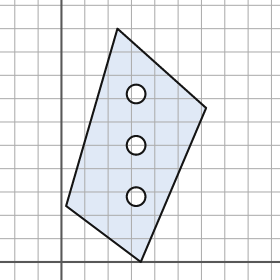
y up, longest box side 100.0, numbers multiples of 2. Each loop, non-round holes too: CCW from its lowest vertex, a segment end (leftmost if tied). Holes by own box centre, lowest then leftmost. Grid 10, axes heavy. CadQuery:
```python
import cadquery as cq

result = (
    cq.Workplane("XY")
    .moveTo(34.0, 0.0)
    .lineTo(62.0, 66.0)
    .lineTo(24.0, 100.0)
    .lineTo(2.0, 24.0)
    .close()
    .moveTo(32.0, 28.0)
    .circle(4.0)
    .moveTo(32.0, 50.0)
    .circle(4.0)
    .moveTo(32.0, 72.0)
    .circle(4.0)
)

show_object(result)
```